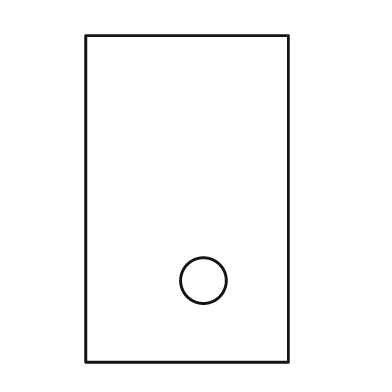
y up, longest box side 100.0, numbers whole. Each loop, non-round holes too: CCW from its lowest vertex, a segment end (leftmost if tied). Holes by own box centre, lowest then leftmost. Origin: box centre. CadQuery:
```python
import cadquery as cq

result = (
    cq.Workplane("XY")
    .moveTo(-31.0, -50.0)
    .lineTo(31.0, -50.0)
    .lineTo(31.0, 50.0)
    .lineTo(-31.0, 50.0)
    .close()
    .moveTo(5.0, -25.0)
    .circle(7.0)
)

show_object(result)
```